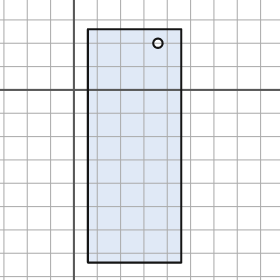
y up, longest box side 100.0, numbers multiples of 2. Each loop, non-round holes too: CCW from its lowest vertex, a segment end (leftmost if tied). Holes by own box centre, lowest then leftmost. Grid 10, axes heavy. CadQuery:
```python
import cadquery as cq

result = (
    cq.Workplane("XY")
    .moveTo(6.0, -74.0)
    .lineTo(46.0, -74.0)
    .lineTo(46.0, 26.0)
    .lineTo(6.0, 26.0)
    .close()
    .moveTo(36.0, 20.0)
    .circle(2.0)
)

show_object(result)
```